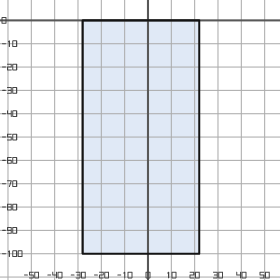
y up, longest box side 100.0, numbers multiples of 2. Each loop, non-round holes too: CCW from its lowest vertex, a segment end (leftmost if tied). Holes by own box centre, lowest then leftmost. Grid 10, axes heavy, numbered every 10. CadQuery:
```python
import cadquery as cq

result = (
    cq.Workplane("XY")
    .moveTo(-28.0, -100.0)
    .lineTo(22.0, -100.0)
    .lineTo(22.0, 0.0)
    .lineTo(-28.0, 0.0)
    .close()
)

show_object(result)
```